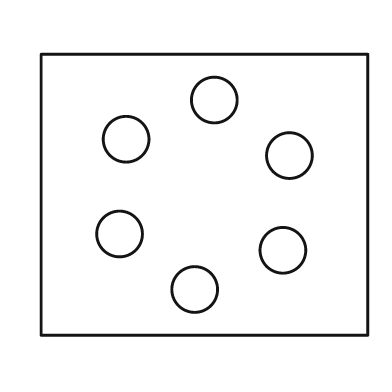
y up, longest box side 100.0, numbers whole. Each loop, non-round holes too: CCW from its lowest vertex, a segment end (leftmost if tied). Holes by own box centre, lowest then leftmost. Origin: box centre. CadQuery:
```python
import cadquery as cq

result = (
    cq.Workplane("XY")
    .moveTo(-50.0, -43.0)
    .lineTo(50.0, -43.0)
    .lineTo(50.0, 43.0)
    .lineTo(-50.0, 43.0)
    .close()
    .moveTo(-3.0, -29.0)
    .circle(7.0)
    .moveTo(24.0, -17.0)
    .circle(7.0)
    .moveTo(-26.0, -12.0)
    .circle(7.0)
    .moveTo(26.0, 12.0)
    .circle(7.0)
    .moveTo(-24.0, 17.0)
    .circle(7.0)
    .moveTo(3.0, 29.0)
    .circle(7.0)
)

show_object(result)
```